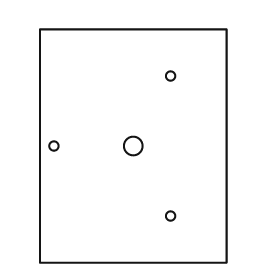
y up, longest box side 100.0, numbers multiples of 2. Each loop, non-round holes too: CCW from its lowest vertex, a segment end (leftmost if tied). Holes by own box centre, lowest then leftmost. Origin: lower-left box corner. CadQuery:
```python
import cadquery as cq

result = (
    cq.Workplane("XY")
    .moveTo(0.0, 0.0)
    .lineTo(80.0, 0.0)
    .lineTo(80.0, 100.0)
    .lineTo(0.0, 100.0)
    .close()
    .moveTo(56.0, 20.0)
    .circle(2.0)
    .moveTo(6.0, 50.0)
    .circle(2.0)
    .moveTo(40.0, 50.0)
    .circle(4.0)
    .moveTo(56.0, 80.0)
    .circle(2.0)
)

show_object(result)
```